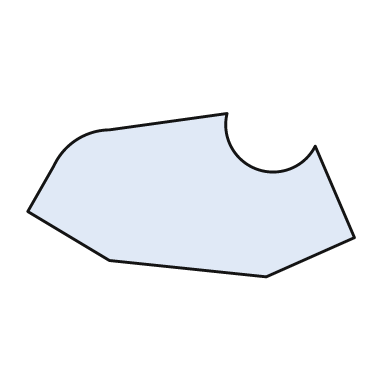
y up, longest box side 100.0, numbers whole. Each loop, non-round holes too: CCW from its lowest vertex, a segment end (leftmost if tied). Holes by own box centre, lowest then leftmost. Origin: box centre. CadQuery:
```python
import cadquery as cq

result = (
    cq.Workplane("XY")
    .moveTo(23.0, -25.0)
    .lineTo(50.0, -13.0)
    .lineTo(38.0, 15.0)
    .threePointArc((20.0, 8.0), (11.0, 25.0))
    .lineTo(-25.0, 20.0)
    .threePointArc((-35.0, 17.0), (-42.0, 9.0))
    .lineTo(-50.0, -5.0)
    .lineTo(-25.0, -20.0)
    .close()
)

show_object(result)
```